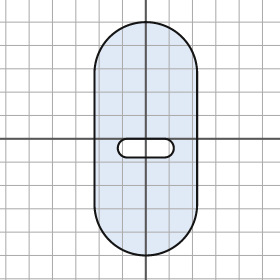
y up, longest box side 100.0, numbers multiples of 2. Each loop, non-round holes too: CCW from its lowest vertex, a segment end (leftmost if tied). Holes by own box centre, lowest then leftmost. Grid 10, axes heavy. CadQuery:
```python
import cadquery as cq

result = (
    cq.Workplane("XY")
    .moveTo(-22.0, -28.0)
    .threePointArc((0.0, -50.0), (22.0, -28.0))
    .lineTo(22.0, 28.0)
    .threePointArc((0.0, 50.0), (-22.0, 28.0))
    .close()
    .moveTo(-8.0, -8.0)
    .lineTo(8.0, -8.0)
    .threePointArc((12.0, -4.0), (8.0, 0.0))
    .lineTo(-8.0, 0.0)
    .threePointArc((-12.0, -4.0), (-8.0, -8.0))
    .close()
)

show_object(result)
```